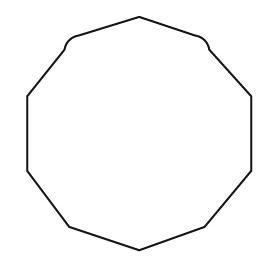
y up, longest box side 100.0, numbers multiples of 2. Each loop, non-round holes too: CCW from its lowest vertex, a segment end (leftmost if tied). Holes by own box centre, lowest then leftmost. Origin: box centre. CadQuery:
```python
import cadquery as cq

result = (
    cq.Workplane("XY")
    .moveTo(0.0, -50.0)
    .lineTo(28.0, -40.0)
    .lineTo(48.0, -16.0)
    .lineTo(48.0, 16.0)
    .lineTo(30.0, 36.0)
    .threePointArc((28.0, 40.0), (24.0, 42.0))
    .lineTo(0.0, 50.0)
    .lineTo(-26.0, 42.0)
    .threePointArc((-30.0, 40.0), (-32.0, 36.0))
    .lineTo(-48.0, 16.0)
    .lineTo(-48.0, -16.0)
    .lineTo(-30.0, -40.0)
    .close()
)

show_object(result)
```